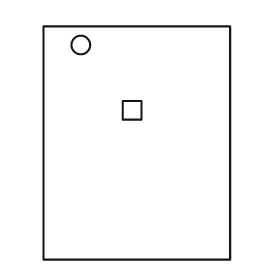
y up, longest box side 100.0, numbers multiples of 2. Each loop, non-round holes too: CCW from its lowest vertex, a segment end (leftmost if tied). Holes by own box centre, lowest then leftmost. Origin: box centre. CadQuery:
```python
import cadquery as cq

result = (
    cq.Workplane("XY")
    .moveTo(-40.0, -50.0)
    .lineTo(40.0, -50.0)
    .lineTo(40.0, 50.0)
    .lineTo(-40.0, 50.0)
    .close()
    .moveTo(-6.0, 10.0)
    .lineTo(2.0, 10.0)
    .lineTo(2.0, 18.0)
    .lineTo(-6.0, 18.0)
    .close()
    .moveTo(-24.0, 42.0)
    .circle(4.0)
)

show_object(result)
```